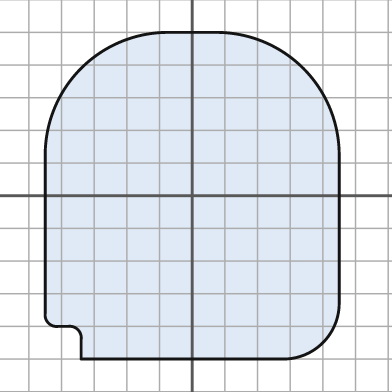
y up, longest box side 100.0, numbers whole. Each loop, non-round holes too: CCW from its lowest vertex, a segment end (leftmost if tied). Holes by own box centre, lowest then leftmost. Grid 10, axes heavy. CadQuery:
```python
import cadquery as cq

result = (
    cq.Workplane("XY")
    .moveTo(-34.0, -50.0)
    .lineTo(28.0, -50.0)
    .threePointArc((40.0, -45.0), (45.0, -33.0))
    .lineTo(45.0, 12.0)
    .threePointArc((34.0, 39.0), (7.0, 50.0))
    .lineTo(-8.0, 50.0)
    .threePointArc((-34.0, 39.0), (-45.0, 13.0))
    .lineTo(-45.0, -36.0)
    .threePointArc((-44.0, -39.0), (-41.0, -40.0))
    .lineTo(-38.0, -40.0)
    .threePointArc((-35.0, -41.0), (-34.0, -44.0))
    .close()
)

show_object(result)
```